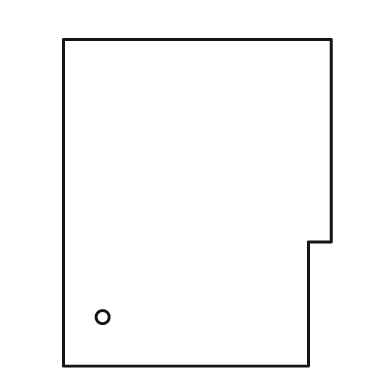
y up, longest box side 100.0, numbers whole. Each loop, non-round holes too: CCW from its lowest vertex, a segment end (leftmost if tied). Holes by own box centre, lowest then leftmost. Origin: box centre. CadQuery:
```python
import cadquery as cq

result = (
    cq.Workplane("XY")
    .moveTo(-41.0, -50.0)
    .lineTo(34.0, -50.0)
    .lineTo(34.0, -12.0)
    .lineTo(41.0, -12.0)
    .lineTo(41.0, 50.0)
    .lineTo(-41.0, 50.0)
    .close()
    .moveTo(-29.0, -35.0)
    .circle(2.0)
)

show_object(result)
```